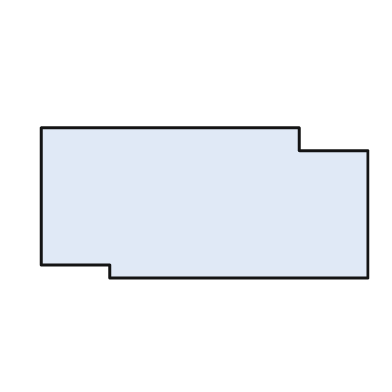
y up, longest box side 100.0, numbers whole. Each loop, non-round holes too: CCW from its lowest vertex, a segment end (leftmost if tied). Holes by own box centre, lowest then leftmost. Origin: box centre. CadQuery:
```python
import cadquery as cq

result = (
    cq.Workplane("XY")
    .moveTo(-29.0, -23.0)
    .lineTo(50.0, -23.0)
    .lineTo(50.0, 16.0)
    .lineTo(29.0, 16.0)
    .lineTo(29.0, 23.0)
    .lineTo(-50.0, 23.0)
    .lineTo(-50.0, -19.0)
    .lineTo(-29.0, -19.0)
    .close()
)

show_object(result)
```